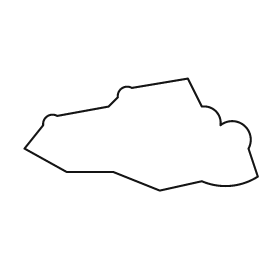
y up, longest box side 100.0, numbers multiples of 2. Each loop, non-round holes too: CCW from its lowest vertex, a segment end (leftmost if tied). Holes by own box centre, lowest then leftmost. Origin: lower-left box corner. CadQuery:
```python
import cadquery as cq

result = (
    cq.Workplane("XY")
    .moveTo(58.0, 0.0)
    .lineTo(76.0, 4.0)
    .threePointArc((88.0, 2.0), (100.0, 6.0))
    .lineTo(96.0, 18.0)
    .threePointArc((94.0, 28.0), (84.0, 28.0))
    .threePointArc((82.0, 34.0), (76.0, 36.0))
    .lineTo(70.0, 48.0)
    .lineTo(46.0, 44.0)
    .threePointArc((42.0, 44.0), (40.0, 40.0))
    .lineTo(36.0, 36.0)
    .lineTo(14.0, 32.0)
    .threePointArc((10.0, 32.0), (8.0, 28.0))
    .lineTo(0.0, 18.0)
    .lineTo(18.0, 8.0)
    .lineTo(38.0, 8.0)
    .close()
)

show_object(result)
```